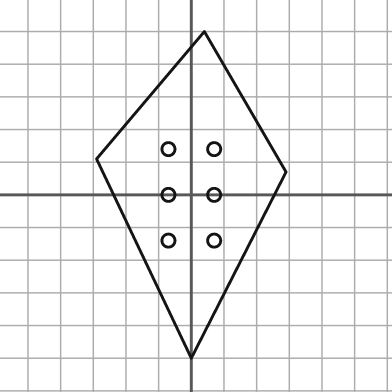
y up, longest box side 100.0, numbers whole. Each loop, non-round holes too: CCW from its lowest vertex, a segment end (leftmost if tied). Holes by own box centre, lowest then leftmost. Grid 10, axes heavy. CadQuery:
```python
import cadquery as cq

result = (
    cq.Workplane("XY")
    .moveTo(0.0, -50.0)
    .lineTo(29.0, 7.0)
    .lineTo(4.0, 50.0)
    .lineTo(-29.0, 11.0)
    .close()
    .moveTo(-7.0, -14.0)
    .circle(2.0)
    .moveTo(7.0, -14.0)
    .circle(2.0)
    .moveTo(-7.0, 0.0)
    .circle(2.0)
    .moveTo(7.0, 0.0)
    .circle(2.0)
    .moveTo(-7.0, 14.0)
    .circle(2.0)
    .moveTo(7.0, 14.0)
    .circle(2.0)
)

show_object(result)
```